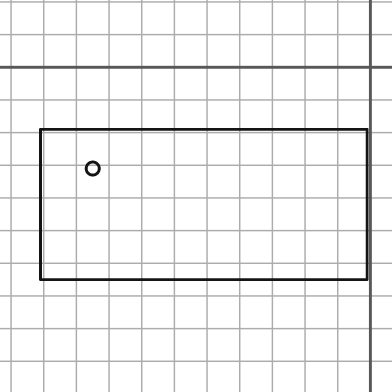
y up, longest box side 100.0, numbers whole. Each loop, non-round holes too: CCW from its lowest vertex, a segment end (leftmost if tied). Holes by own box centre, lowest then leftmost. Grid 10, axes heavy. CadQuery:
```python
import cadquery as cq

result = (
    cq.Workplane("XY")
    .moveTo(-101.0, -65.0)
    .lineTo(-1.0, -65.0)
    .lineTo(-1.0, -19.0)
    .lineTo(-101.0, -19.0)
    .close()
    .moveTo(-85.0, -31.0)
    .circle(2.0)
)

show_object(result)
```